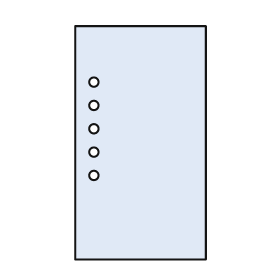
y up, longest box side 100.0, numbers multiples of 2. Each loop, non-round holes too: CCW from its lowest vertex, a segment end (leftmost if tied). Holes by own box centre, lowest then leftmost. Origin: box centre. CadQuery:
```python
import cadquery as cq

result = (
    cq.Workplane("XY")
    .moveTo(-28.0, -50.0)
    .lineTo(28.0, -50.0)
    .lineTo(28.0, 50.0)
    .lineTo(-28.0, 50.0)
    .close()
    .moveTo(-20.0, -14.0)
    .circle(2.0)
    .moveTo(-20.0, -4.0)
    .circle(2.0)
    .moveTo(-20.0, 6.0)
    .circle(2.0)
    .moveTo(-20.0, 16.0)
    .circle(2.0)
    .moveTo(-20.0, 26.0)
    .circle(2.0)
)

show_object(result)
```